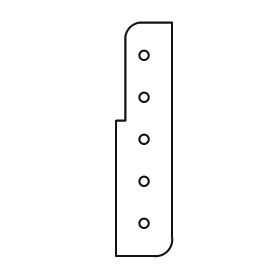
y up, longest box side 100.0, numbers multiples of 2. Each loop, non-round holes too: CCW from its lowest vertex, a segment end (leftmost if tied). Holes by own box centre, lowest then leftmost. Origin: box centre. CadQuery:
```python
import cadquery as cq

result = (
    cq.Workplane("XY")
    .moveTo(-12.0, -50.0)
    .lineTo(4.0, -50.0)
    .threePointArc((10.0, -48.0), (12.0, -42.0))
    .lineTo(12.0, 50.0)
    .lineTo(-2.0, 50.0)
    .threePointArc((-6.0, 48.0), (-8.0, 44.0))
    .lineTo(-8.0, 8.0)
    .lineTo(-12.0, 8.0)
    .close()
    .moveTo(0.0, -36.0)
    .circle(2.0)
    .moveTo(0.0, -18.0)
    .circle(2.0)
    .moveTo(0.0, 0.0)
    .circle(2.0)
    .moveTo(0.0, 18.0)
    .circle(2.0)
    .moveTo(0.0, 36.0)
    .circle(2.0)
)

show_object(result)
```